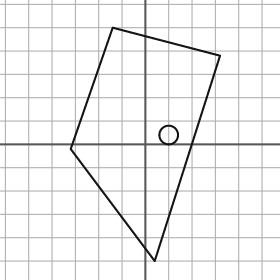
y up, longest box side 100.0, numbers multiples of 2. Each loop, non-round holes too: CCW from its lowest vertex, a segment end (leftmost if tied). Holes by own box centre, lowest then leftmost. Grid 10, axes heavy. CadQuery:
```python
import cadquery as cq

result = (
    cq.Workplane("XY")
    .moveTo(4.0, -50.0)
    .lineTo(32.0, 38.0)
    .lineTo(-14.0, 50.0)
    .lineTo(-32.0, -2.0)
    .close()
    .moveTo(10.0, 4.0)
    .circle(4.0)
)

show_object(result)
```